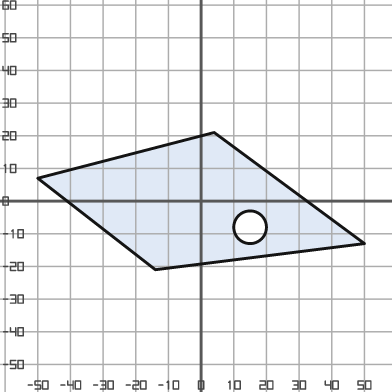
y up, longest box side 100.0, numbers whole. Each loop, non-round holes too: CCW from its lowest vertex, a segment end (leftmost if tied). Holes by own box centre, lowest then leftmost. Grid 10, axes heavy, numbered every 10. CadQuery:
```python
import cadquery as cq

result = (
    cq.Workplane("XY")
    .moveTo(-14.0, -21.0)
    .lineTo(50.0, -13.0)
    .lineTo(4.0, 21.0)
    .lineTo(-50.0, 7.0)
    .close()
    .moveTo(15.0, -8.0)
    .circle(5.0)
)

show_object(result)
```